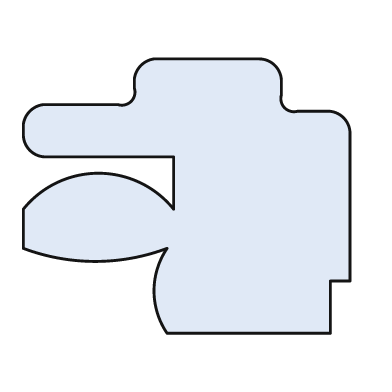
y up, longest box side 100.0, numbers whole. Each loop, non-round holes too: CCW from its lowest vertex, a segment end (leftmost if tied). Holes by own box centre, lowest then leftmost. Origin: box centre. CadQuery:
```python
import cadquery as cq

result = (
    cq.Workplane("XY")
    .moveTo(-6.0, -42.0)
    .lineTo(44.0, -42.0)
    .lineTo(44.0, -26.0)
    .lineTo(50.0, -26.0)
    .lineTo(50.0, 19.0)
    .threePointArc((48.0, 24.0), (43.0, 26.0))
    .lineTo(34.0, 26.0)
    .threePointArc((30.0, 27.0), (29.0, 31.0))
    .lineTo(29.0, 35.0)
    .threePointArc((27.0, 40.0), (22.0, 42.0))
    .lineTo(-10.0, 42.0)
    .threePointArc((-14.0, 40.0), (-16.0, 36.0))
    .lineTo(-16.0, 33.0)
    .threePointArc((-17.0, 29.0), (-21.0, 28.0))
    .lineTo(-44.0, 28.0)
    .threePointArc((-48.0, 26.0), (-50.0, 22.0))
    .lineTo(-50.0, 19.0)
    .threePointArc((-48.0, 14.0), (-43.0, 12.0))
    .lineTo(-4.0, 12.0)
    .lineTo(-4.0, -4.0)
    .threePointArc((-27.0, 7.0), (-50.0, -4.0))
    .lineTo(-50.0, -16.0)
    .threePointArc((-28.0, -20.0), (-6.0, -16.0))
    .threePointArc((-10.0, -29.0), (-6.0, -42.0))
    .close()
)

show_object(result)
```